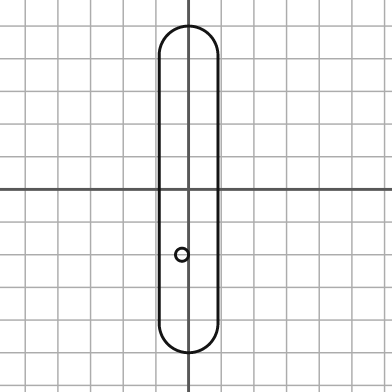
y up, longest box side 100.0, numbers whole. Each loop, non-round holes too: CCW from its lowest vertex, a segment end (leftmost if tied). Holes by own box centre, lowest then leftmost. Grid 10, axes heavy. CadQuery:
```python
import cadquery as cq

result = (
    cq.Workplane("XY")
    .moveTo(-9.0, -41.0)
    .threePointArc((0.0, -50.0), (9.0, -41.0))
    .lineTo(9.0, 41.0)
    .threePointArc((0.0, 50.0), (-9.0, 41.0))
    .close()
    .moveTo(-2.0, -20.0)
    .circle(2.0)
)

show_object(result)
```